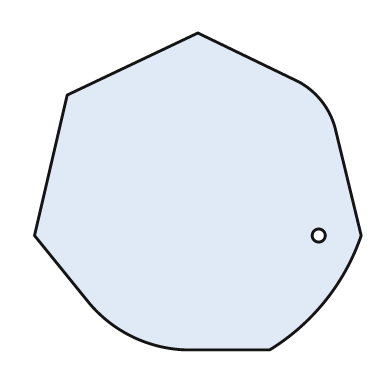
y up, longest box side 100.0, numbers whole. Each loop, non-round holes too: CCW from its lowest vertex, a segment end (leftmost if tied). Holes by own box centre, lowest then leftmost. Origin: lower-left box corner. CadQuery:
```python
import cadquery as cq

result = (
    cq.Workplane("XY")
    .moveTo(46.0, 0.0)
    .lineTo(72.0, 0.0)
    .threePointArc((89.0, 15.0), (100.0, 35.0))
    .lineTo(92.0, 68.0)
    .threePointArc((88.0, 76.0), (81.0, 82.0))
    .lineTo(50.0, 97.0)
    .lineTo(10.0, 78.0)
    .lineTo(0.0, 35.0)
    .lineTo(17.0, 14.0)
    .threePointArc((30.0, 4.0), (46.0, 0.0))
    .close()
    .moveTo(87.0, 35.0)
    .circle(2.0)
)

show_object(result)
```